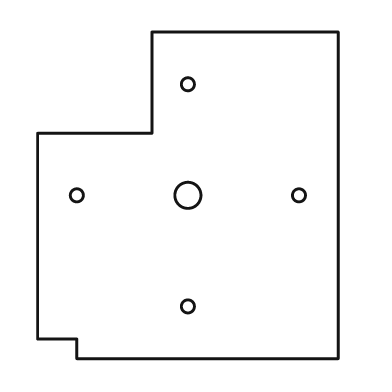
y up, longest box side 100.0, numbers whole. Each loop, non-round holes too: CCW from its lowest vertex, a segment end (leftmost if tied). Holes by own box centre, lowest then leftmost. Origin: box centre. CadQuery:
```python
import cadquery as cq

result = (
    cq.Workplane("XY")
    .moveTo(-34.0, -50.0)
    .lineTo(46.0, -50.0)
    .lineTo(46.0, 50.0)
    .lineTo(-11.0, 50.0)
    .lineTo(-11.0, 19.0)
    .lineTo(-46.0, 19.0)
    .lineTo(-46.0, -44.0)
    .lineTo(-34.0, -44.0)
    .close()
    .moveTo(0.0, -34.0)
    .circle(2.0)
    .moveTo(-34.0, 0.0)
    .circle(2.0)
    .moveTo(0.0, 0.0)
    .circle(4.0)
    .moveTo(34.0, 0.0)
    .circle(2.0)
    .moveTo(0.0, 34.0)
    .circle(2.0)
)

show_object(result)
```